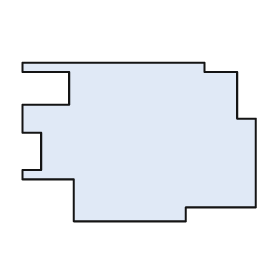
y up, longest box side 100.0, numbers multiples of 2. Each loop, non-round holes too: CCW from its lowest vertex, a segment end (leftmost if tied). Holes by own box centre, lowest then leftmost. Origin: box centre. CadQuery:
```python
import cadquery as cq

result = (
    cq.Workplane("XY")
    .moveTo(-28.0, -34.0)
    .lineTo(20.0, -34.0)
    .lineTo(20.0, -28.0)
    .lineTo(50.0, -28.0)
    .lineTo(50.0, 10.0)
    .lineTo(42.0, 10.0)
    .lineTo(42.0, 30.0)
    .lineTo(28.0, 30.0)
    .lineTo(28.0, 34.0)
    .lineTo(-50.0, 34.0)
    .lineTo(-50.0, 30.0)
    .lineTo(-30.0, 30.0)
    .lineTo(-30.0, 16.0)
    .lineTo(-50.0, 16.0)
    .lineTo(-50.0, 4.0)
    .lineTo(-42.0, 4.0)
    .lineTo(-42.0, -12.0)
    .lineTo(-50.0, -12.0)
    .lineTo(-50.0, -16.0)
    .lineTo(-28.0, -16.0)
    .close()
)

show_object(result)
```